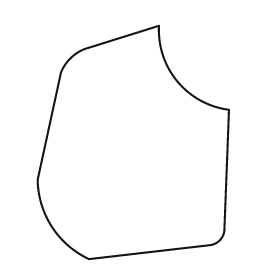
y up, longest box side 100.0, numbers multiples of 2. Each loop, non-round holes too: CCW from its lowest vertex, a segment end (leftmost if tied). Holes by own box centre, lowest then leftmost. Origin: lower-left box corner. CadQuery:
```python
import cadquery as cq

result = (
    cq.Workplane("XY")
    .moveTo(22.0, 0.0)
    .lineTo(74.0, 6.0)
    .threePointArc((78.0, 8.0), (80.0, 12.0))
    .lineTo(82.0, 64.0)
    .threePointArc((60.0, 76.0), (52.0, 100.0))
    .lineTo(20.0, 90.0)
    .threePointArc((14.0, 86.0), (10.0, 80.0))
    .lineTo(0.0, 34.0)
    .threePointArc((6.0, 14.0), (22.0, 0.0))
    .close()
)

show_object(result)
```